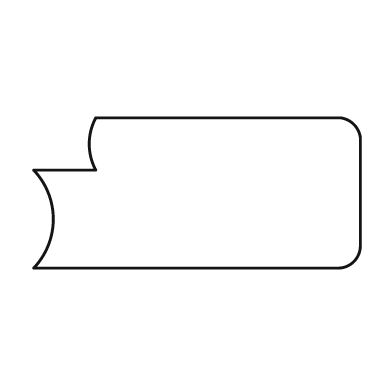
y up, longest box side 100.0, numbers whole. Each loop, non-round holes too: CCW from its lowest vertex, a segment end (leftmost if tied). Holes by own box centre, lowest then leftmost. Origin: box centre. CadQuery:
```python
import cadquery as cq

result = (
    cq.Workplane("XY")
    .moveTo(-50.0, -23.0)
    .lineTo(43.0, -23.0)
    .threePointArc((48.0, -21.0), (50.0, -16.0))
    .lineTo(50.0, 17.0)
    .threePointArc((48.0, 21.0), (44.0, 23.0))
    .lineTo(-31.0, 23.0)
    .threePointArc((-33.0, 15.0), (-31.0, 7.0))
    .lineTo(-50.0, 7.0)
    .threePointArc((-44.0, -8.0), (-50.0, -23.0))
    .close()
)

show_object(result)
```